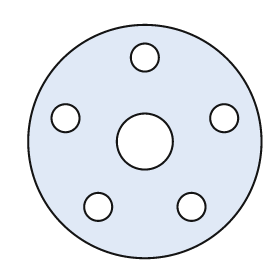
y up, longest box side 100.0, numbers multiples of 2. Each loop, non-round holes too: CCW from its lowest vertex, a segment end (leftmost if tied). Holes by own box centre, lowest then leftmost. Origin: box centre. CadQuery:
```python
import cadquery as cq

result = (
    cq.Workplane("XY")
    .moveTo(0.0, 0.0)
    .circle(50.0)
    .moveTo(-20.0, -28.0)
    .circle(6.0)
    .moveTo(20.0, -28.0)
    .circle(6.0)
    .moveTo(0.0, 0.0)
    .circle(12.0)
    .moveTo(-34.0, 10.0)
    .circle(6.0)
    .moveTo(34.0, 10.0)
    .circle(6.0)
    .moveTo(0.0, 36.0)
    .circle(6.0)
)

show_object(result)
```